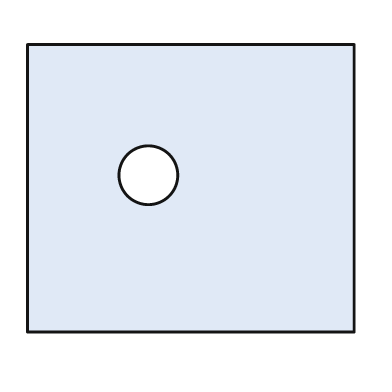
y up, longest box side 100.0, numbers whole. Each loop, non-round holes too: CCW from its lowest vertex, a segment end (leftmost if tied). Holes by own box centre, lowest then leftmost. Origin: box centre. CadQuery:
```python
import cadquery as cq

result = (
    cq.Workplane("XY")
    .moveTo(-50.0, -44.0)
    .lineTo(50.0, -44.0)
    .lineTo(50.0, 44.0)
    .lineTo(-50.0, 44.0)
    .close()
    .moveTo(-13.0, 4.0)
    .circle(9.0)
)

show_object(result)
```